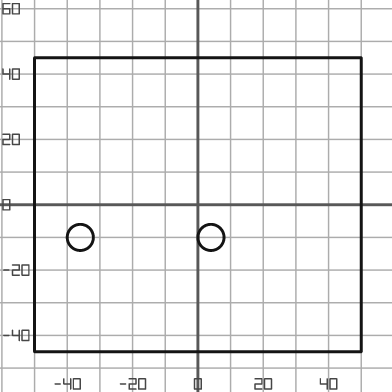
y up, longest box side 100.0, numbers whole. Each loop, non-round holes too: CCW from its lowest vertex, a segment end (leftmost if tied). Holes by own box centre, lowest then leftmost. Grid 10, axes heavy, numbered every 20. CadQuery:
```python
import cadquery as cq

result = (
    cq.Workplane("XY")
    .moveTo(-50.0, -45.0)
    .lineTo(50.0, -45.0)
    .lineTo(50.0, 45.0)
    .lineTo(-50.0, 45.0)
    .close()
    .moveTo(-36.0, -10.0)
    .circle(4.0)
    .moveTo(4.0, -10.0)
    .circle(4.0)
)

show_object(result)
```